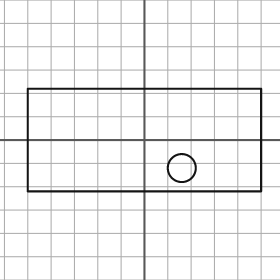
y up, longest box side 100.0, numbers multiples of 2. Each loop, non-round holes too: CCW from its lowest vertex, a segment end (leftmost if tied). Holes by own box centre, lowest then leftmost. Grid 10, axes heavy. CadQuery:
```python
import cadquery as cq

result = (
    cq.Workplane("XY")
    .moveTo(-50.0, -22.0)
    .lineTo(50.0, -22.0)
    .lineTo(50.0, 22.0)
    .lineTo(-50.0, 22.0)
    .close()
    .moveTo(16.0, -12.0)
    .circle(6.0)
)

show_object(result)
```